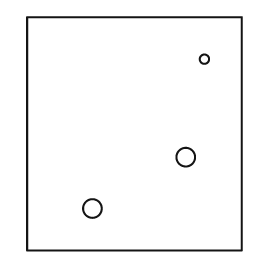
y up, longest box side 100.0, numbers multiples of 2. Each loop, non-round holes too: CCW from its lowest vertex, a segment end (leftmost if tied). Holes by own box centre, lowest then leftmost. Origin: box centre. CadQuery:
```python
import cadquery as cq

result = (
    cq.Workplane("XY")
    .moveTo(-46.0, -50.0)
    .lineTo(46.0, -50.0)
    .lineTo(46.0, 50.0)
    .lineTo(-46.0, 50.0)
    .close()
    .moveTo(-18.0, -32.0)
    .circle(4.0)
    .moveTo(22.0, -10.0)
    .circle(4.0)
    .moveTo(30.0, 32.0)
    .circle(2.0)
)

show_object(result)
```